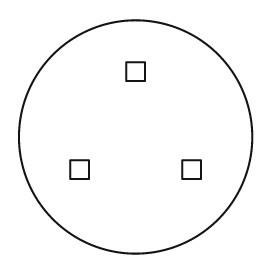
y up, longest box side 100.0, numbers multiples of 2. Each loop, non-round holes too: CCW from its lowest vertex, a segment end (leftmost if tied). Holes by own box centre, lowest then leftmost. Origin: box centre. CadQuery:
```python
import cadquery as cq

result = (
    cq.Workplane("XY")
    .moveTo(0.0, 0.0)
    .circle(50.0)
    .moveTo(-28.0, -18.0)
    .lineTo(-20.0, -18.0)
    .lineTo(-20.0, -10.0)
    .lineTo(-28.0, -10.0)
    .close()
    .moveTo(20.0, -18.0)
    .lineTo(28.0, -18.0)
    .lineTo(28.0, -10.0)
    .lineTo(20.0, -10.0)
    .close()
    .moveTo(-4.0, 24.0)
    .lineTo(4.0, 24.0)
    .lineTo(4.0, 32.0)
    .lineTo(-4.0, 32.0)
    .close()
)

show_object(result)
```